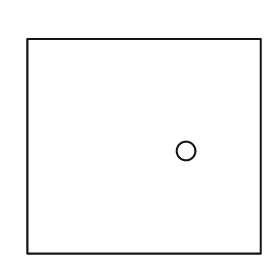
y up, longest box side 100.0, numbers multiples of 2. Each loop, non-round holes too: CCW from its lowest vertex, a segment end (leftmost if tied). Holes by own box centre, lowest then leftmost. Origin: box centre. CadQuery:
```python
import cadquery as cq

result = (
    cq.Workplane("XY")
    .moveTo(-50.0, -46.0)
    .lineTo(50.0, -46.0)
    .lineTo(50.0, 46.0)
    .lineTo(-50.0, 46.0)
    .close()
    .moveTo(18.0, -2.0)
    .circle(4.0)
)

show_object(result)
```